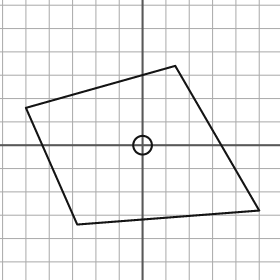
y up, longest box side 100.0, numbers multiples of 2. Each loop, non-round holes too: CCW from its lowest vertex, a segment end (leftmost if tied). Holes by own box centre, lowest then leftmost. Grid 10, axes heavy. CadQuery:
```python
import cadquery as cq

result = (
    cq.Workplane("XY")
    .moveTo(-28.0, -34.0)
    .lineTo(50.0, -28.0)
    .lineTo(14.0, 34.0)
    .lineTo(-50.0, 16.0)
    .close()
    .moveTo(0.0, 0.0)
    .circle(4.0)
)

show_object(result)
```